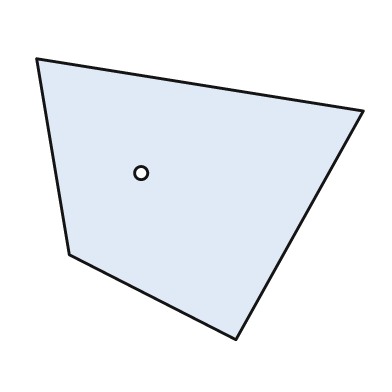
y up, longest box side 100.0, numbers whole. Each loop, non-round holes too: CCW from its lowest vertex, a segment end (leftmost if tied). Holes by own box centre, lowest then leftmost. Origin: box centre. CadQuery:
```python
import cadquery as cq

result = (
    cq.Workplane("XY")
    .moveTo(11.0, -43.0)
    .lineTo(50.0, 27.0)
    .lineTo(-50.0, 43.0)
    .lineTo(-40.0, -17.0)
    .close()
    .moveTo(-18.0, 8.0)
    .circle(2.0)
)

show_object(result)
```